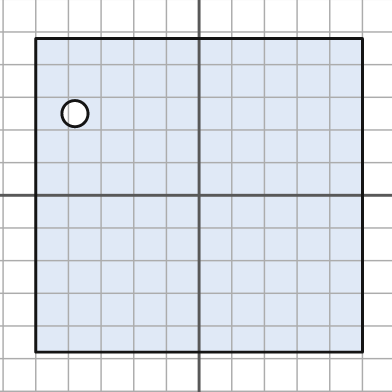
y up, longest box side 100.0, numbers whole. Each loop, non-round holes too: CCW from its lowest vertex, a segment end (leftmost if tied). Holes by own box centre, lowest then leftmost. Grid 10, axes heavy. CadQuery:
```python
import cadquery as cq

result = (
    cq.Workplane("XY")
    .moveTo(-50.0, -48.0)
    .lineTo(50.0, -48.0)
    .lineTo(50.0, 48.0)
    .lineTo(-50.0, 48.0)
    .close()
    .moveTo(-38.0, 25.0)
    .circle(4.0)
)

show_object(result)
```